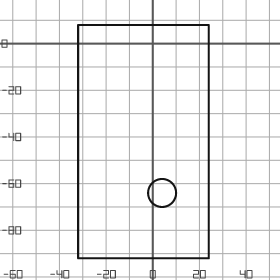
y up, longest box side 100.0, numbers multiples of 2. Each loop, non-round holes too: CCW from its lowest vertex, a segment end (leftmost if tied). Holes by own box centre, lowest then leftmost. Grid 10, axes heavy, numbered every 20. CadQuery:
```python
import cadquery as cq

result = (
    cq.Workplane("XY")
    .moveTo(-32.0, -92.0)
    .lineTo(24.0, -92.0)
    .lineTo(24.0, 8.0)
    .lineTo(-32.0, 8.0)
    .close()
    .moveTo(4.0, -64.0)
    .circle(6.0)
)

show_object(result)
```